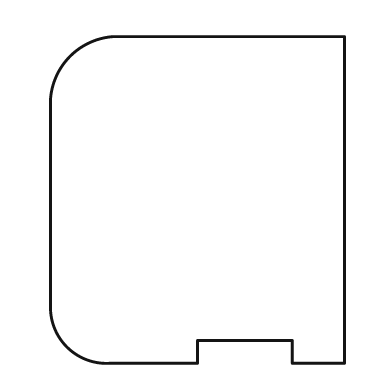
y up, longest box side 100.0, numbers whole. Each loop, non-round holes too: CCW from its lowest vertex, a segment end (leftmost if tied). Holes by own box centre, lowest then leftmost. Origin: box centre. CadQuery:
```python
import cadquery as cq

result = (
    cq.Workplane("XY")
    .moveTo(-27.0, -50.0)
    .lineTo(0.0, -50.0)
    .lineTo(0.0, -43.0)
    .lineTo(29.0, -43.0)
    .lineTo(29.0, -50.0)
    .lineTo(45.0, -50.0)
    .lineTo(45.0, 50.0)
    .lineTo(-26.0, 50.0)
    .threePointArc((-39.0, 44.0), (-45.0, 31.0))
    .lineTo(-45.0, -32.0)
    .threePointArc((-40.0, -45.0), (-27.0, -50.0))
    .close()
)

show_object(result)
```